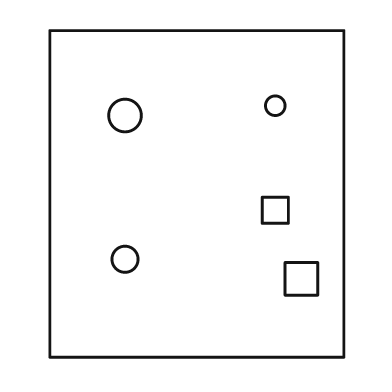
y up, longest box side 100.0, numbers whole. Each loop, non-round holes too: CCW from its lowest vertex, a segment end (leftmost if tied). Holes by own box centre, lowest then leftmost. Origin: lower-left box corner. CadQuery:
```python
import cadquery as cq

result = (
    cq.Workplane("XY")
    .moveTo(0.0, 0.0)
    .lineTo(90.0, 0.0)
    .lineTo(90.0, 100.0)
    .lineTo(0.0, 100.0)
    .close()
    .moveTo(72.0, 19.0)
    .lineTo(82.0, 19.0)
    .lineTo(82.0, 29.0)
    .lineTo(72.0, 29.0)
    .close()
    .moveTo(23.0, 30.0)
    .circle(4.0)
    .moveTo(65.0, 41.0)
    .lineTo(73.0, 41.0)
    .lineTo(73.0, 49.0)
    .lineTo(65.0, 49.0)
    .close()
    .moveTo(23.0, 74.0)
    .circle(5.0)
    .moveTo(69.0, 77.0)
    .circle(3.0)
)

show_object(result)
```